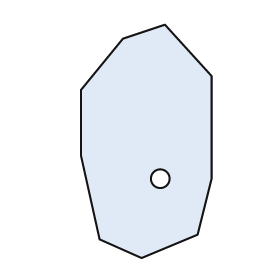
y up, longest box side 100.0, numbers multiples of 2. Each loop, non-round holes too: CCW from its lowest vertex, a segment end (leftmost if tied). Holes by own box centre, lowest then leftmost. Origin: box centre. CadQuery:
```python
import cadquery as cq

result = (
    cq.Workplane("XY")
    .moveTo(-2.0, -50.0)
    .lineTo(22.0, -40.0)
    .lineTo(28.0, -16.0)
    .lineTo(28.0, 28.0)
    .lineTo(8.0, 50.0)
    .lineTo(-10.0, 44.0)
    .lineTo(-28.0, 22.0)
    .lineTo(-28.0, -6.0)
    .lineTo(-20.0, -42.0)
    .close()
    .moveTo(6.0, -16.0)
    .circle(4.0)
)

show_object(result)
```